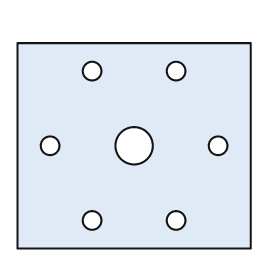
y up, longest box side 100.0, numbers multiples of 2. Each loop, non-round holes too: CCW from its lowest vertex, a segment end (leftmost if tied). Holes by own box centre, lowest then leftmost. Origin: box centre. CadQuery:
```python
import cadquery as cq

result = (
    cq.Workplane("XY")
    .moveTo(-50.0, -44.0)
    .lineTo(50.0, -44.0)
    .lineTo(50.0, 44.0)
    .lineTo(-50.0, 44.0)
    .close()
    .moveTo(-18.0, -32.0)
    .circle(4.0)
    .moveTo(18.0, -32.0)
    .circle(4.0)
    .moveTo(-36.0, 0.0)
    .circle(4.0)
    .moveTo(0.0, 0.0)
    .circle(8.0)
    .moveTo(36.0, 0.0)
    .circle(4.0)
    .moveTo(-18.0, 32.0)
    .circle(4.0)
    .moveTo(18.0, 32.0)
    .circle(4.0)
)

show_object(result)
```